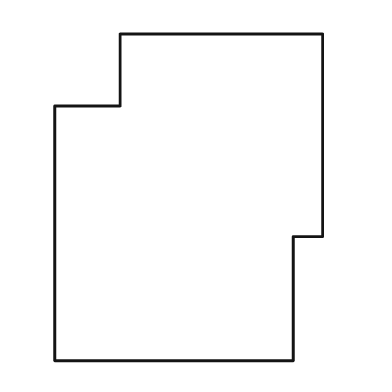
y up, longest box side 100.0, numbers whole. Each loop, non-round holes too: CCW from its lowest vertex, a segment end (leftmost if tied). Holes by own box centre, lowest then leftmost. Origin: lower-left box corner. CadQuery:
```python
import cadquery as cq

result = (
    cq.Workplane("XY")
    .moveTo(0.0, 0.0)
    .lineTo(73.0, 0.0)
    .lineTo(73.0, 38.0)
    .lineTo(82.0, 38.0)
    .lineTo(82.0, 100.0)
    .lineTo(20.0, 100.0)
    .lineTo(20.0, 78.0)
    .lineTo(0.0, 78.0)
    .close()
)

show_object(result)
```